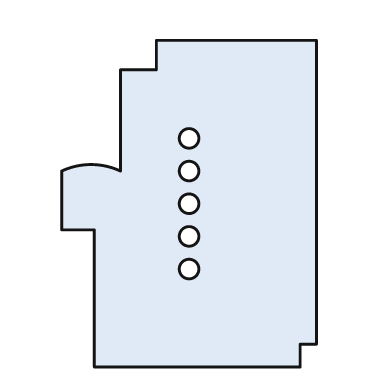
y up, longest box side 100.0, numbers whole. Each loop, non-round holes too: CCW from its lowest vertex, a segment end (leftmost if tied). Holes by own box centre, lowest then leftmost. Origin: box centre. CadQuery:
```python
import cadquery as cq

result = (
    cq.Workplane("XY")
    .moveTo(-29.0, -50.0)
    .lineTo(34.0, -50.0)
    .lineTo(34.0, -43.0)
    .lineTo(39.0, -43.0)
    .lineTo(39.0, 50.0)
    .lineTo(-10.0, 50.0)
    .lineTo(-10.0, 41.0)
    .lineTo(-21.0, 41.0)
    .lineTo(-21.0, 10.0)
    .threePointArc((-30.0, 12.0), (-39.0, 10.0))
    .lineTo(-39.0, -8.0)
    .lineTo(-29.0, -8.0)
    .close()
    .moveTo(0.0, -20.0)
    .circle(3.0)
    .moveTo(0.0, -10.0)
    .circle(3.0)
    .moveTo(0.0, 0.0)
    .circle(3.0)
    .moveTo(0.0, 10.0)
    .circle(3.0)
    .moveTo(0.0, 20.0)
    .circle(3.0)
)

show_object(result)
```